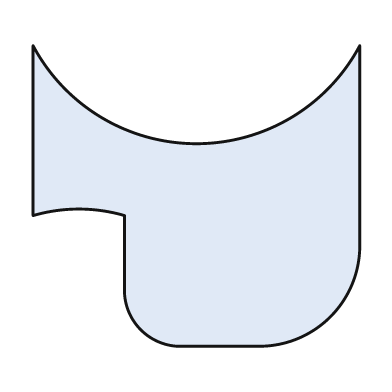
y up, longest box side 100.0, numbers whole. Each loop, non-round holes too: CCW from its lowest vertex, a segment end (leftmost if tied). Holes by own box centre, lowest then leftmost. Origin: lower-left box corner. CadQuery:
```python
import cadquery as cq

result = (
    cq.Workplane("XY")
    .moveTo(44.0, 0.0)
    .lineTo(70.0, 0.0)
    .threePointArc((91.0, 9.0), (100.0, 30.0))
    .lineTo(100.0, 92.0)
    .threePointArc((50.0, 62.0), (0.0, 92.0))
    .lineTo(0.0, 40.0)
    .threePointArc((14.0, 42.0), (28.0, 40.0))
    .lineTo(28.0, 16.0)
    .threePointArc((33.0, 5.0), (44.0, 0.0))
    .close()
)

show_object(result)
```